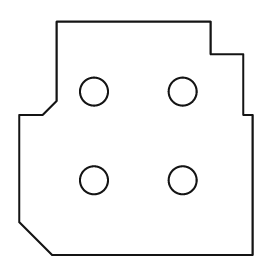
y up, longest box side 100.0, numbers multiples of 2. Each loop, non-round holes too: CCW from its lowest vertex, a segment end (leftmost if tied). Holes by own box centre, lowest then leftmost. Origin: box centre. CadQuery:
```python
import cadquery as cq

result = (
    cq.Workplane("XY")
    .moveTo(-36.0, -50.0)
    .lineTo(50.0, -50.0)
    .lineTo(50.0, 10.0)
    .lineTo(46.0, 10.0)
    .lineTo(46.0, 36.0)
    .lineTo(32.0, 36.0)
    .lineTo(32.0, 50.0)
    .lineTo(-34.0, 50.0)
    .lineTo(-34.0, 16.0)
    .lineTo(-40.0, 10.0)
    .lineTo(-50.0, 10.0)
    .lineTo(-50.0, -36.0)
    .close()
    .moveTo(-18.0, -18.0)
    .circle(6.0)
    .moveTo(20.0, -18.0)
    .circle(6.0)
    .moveTo(-18.0, 20.0)
    .circle(6.0)
    .moveTo(20.0, 20.0)
    .circle(6.0)
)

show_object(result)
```